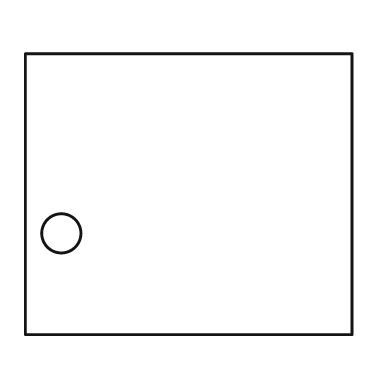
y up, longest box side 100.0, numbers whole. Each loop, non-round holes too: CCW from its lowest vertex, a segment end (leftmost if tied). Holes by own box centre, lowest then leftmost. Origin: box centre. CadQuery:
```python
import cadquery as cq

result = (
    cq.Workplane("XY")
    .moveTo(-50.0, -43.0)
    .lineTo(50.0, -43.0)
    .lineTo(50.0, 43.0)
    .lineTo(-50.0, 43.0)
    .close()
    .moveTo(-39.0, -12.0)
    .circle(6.0)
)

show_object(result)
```